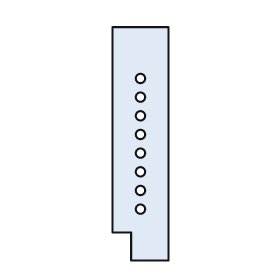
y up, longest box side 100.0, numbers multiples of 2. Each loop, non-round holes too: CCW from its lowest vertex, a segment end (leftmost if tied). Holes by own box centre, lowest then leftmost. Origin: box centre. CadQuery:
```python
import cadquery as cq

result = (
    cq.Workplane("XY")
    .moveTo(-4.0, -50.0)
    .lineTo(12.0, -50.0)
    .lineTo(12.0, 50.0)
    .lineTo(-12.0, 50.0)
    .lineTo(-12.0, -38.0)
    .lineTo(-4.0, -38.0)
    .close()
    .moveTo(0.0, -28.0)
    .circle(2.0)
    .moveTo(0.0, -20.0)
    .circle(2.0)
    .moveTo(0.0, -12.0)
    .circle(2.0)
    .moveTo(0.0, -4.0)
    .circle(2.0)
    .moveTo(0.0, 4.0)
    .circle(2.0)
    .moveTo(0.0, 12.0)
    .circle(2.0)
    .moveTo(0.0, 20.0)
    .circle(2.0)
    .moveTo(0.0, 28.0)
    .circle(2.0)
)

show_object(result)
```